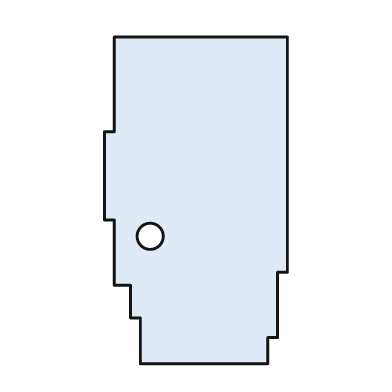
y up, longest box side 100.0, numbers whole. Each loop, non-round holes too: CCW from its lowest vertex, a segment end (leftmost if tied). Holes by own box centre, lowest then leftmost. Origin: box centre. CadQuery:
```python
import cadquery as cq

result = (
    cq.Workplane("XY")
    .moveTo(-17.0, -50.0)
    .lineTo(22.0, -50.0)
    .lineTo(22.0, -42.0)
    .lineTo(25.0, -42.0)
    .lineTo(25.0, -22.0)
    .lineTo(28.0, -22.0)
    .lineTo(28.0, 50.0)
    .lineTo(-25.0, 50.0)
    .lineTo(-25.0, 21.0)
    .lineTo(-28.0, 21.0)
    .lineTo(-28.0, -6.0)
    .lineTo(-25.0, -6.0)
    .lineTo(-25.0, -26.0)
    .lineTo(-20.0, -26.0)
    .lineTo(-20.0, -36.0)
    .lineTo(-17.0, -36.0)
    .close()
    .moveTo(-14.0, -11.0)
    .circle(4.0)
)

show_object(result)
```